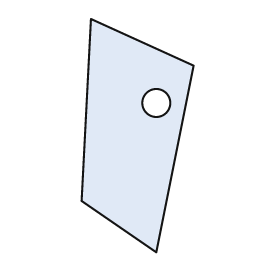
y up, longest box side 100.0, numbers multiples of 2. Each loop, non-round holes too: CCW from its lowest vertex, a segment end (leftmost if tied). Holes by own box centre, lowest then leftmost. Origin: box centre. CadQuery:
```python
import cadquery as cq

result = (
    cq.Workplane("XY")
    .moveTo(8.0, -50.0)
    .lineTo(24.0, 30.0)
    .lineTo(-20.0, 50.0)
    .lineTo(-24.0, -28.0)
    .close()
    .moveTo(8.0, 14.0)
    .circle(6.0)
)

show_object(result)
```